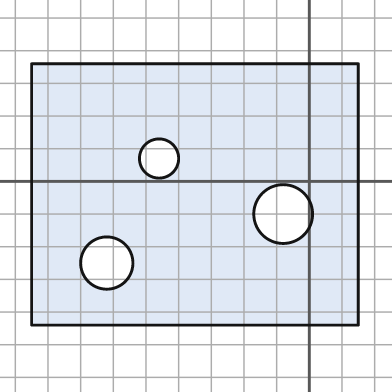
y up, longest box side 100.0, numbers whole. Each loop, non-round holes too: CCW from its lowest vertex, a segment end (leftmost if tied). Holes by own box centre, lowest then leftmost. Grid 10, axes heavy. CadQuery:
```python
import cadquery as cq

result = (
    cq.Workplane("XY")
    .moveTo(-85.0, -44.0)
    .lineTo(15.0, -44.0)
    .lineTo(15.0, 36.0)
    .lineTo(-85.0, 36.0)
    .close()
    .moveTo(-62.0, -25.0)
    .circle(8.0)
    .moveTo(-8.0, -10.0)
    .circle(9.0)
    .moveTo(-46.0, 7.0)
    .circle(6.0)
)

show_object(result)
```